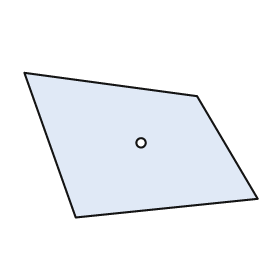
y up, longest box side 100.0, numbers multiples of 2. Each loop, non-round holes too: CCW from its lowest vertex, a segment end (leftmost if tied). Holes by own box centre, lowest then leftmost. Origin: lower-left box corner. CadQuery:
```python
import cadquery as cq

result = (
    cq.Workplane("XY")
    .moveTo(22.0, 0.0)
    .lineTo(100.0, 8.0)
    .lineTo(74.0, 52.0)
    .lineTo(0.0, 62.0)
    .close()
    .moveTo(50.0, 32.0)
    .circle(2.0)
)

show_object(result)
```